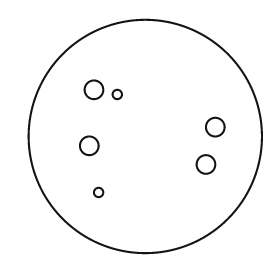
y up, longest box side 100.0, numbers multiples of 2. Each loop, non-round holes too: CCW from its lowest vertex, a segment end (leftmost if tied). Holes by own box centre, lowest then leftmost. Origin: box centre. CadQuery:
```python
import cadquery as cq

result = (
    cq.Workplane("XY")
    .moveTo(0.0, 0.0)
    .circle(50.0)
    .moveTo(-20.0, -24.0)
    .circle(2.0)
    .moveTo(26.0, -12.0)
    .circle(4.0)
    .moveTo(-24.0, -4.0)
    .circle(4.0)
    .moveTo(30.0, 4.0)
    .circle(4.0)
    .moveTo(-12.0, 18.0)
    .circle(2.0)
    .moveTo(-22.0, 20.0)
    .circle(4.0)
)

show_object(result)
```